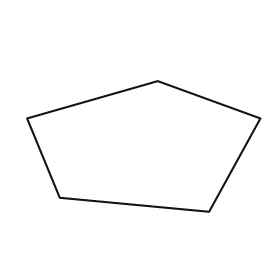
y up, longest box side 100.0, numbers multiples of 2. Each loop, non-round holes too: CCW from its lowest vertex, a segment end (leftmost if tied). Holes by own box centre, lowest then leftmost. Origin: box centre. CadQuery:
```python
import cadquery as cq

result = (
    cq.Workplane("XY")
    .moveTo(28.0, -28.0)
    .lineTo(50.0, 12.0)
    .lineTo(6.0, 28.0)
    .lineTo(-50.0, 12.0)
    .lineTo(-36.0, -22.0)
    .close()
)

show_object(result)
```